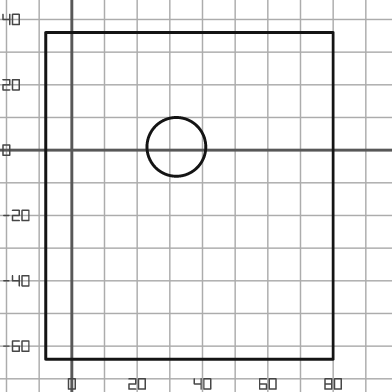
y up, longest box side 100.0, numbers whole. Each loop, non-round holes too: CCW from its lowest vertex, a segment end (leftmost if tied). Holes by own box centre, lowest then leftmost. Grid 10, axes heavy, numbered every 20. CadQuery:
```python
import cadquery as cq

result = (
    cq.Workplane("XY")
    .moveTo(-8.0, -64.0)
    .lineTo(80.0, -64.0)
    .lineTo(80.0, 36.0)
    .lineTo(-8.0, 36.0)
    .close()
    .moveTo(32.0, 1.0)
    .circle(9.0)
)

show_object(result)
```